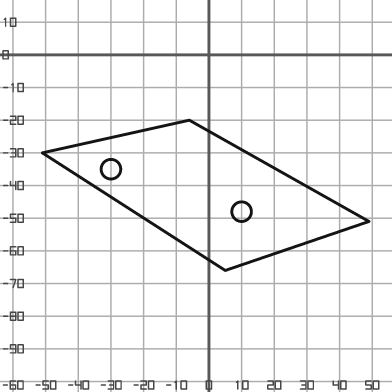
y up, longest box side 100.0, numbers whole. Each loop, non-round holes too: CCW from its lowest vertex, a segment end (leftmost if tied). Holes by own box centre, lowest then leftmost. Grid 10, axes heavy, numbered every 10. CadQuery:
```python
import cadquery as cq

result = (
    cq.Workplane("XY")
    .moveTo(5.0, -66.0)
    .lineTo(49.0, -51.0)
    .lineTo(-6.0, -20.0)
    .lineTo(-51.0, -30.0)
    .close()
    .moveTo(10.0, -48.0)
    .circle(3.0)
    .moveTo(-30.0, -35.0)
    .circle(3.0)
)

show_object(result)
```